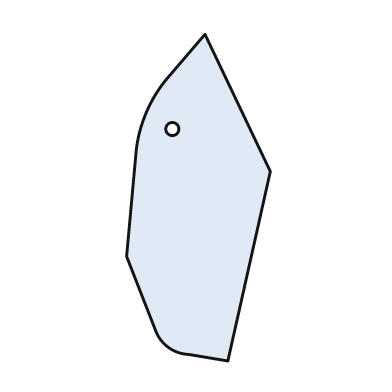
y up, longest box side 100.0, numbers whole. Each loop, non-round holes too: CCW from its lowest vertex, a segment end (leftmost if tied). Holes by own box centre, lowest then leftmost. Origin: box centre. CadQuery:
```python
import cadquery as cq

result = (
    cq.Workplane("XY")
    .moveTo(9.0, -50.0)
    .lineTo(22.0, 8.0)
    .lineTo(2.0, 50.0)
    .lineTo(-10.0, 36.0)
    .threePointArc((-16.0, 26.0), (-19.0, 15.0))
    .lineTo(-22.0, -18.0)
    .lineTo(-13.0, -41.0)
    .threePointArc((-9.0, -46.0), (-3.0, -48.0))
    .close()
    .moveTo(-8.0, 21.0)
    .circle(2.0)
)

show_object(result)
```